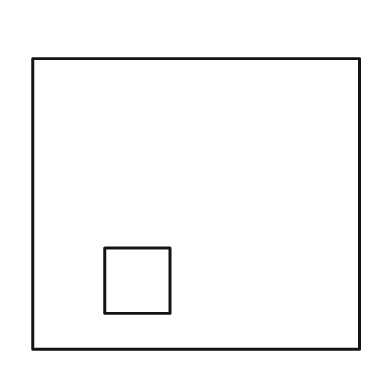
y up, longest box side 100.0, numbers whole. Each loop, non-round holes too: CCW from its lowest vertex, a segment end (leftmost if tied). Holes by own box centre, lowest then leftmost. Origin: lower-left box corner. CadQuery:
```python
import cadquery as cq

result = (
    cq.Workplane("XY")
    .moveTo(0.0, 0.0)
    .lineTo(100.0, 0.0)
    .lineTo(100.0, 89.0)
    .lineTo(0.0, 89.0)
    .close()
    .moveTo(22.0, 11.0)
    .lineTo(42.0, 11.0)
    .lineTo(42.0, 31.0)
    .lineTo(22.0, 31.0)
    .close()
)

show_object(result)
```